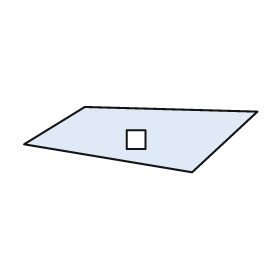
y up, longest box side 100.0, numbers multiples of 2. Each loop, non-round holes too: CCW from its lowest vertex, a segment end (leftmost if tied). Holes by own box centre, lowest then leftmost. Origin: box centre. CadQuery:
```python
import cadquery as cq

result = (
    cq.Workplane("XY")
    .moveTo(22.0, -14.0)
    .lineTo(50.0, 12.0)
    .lineTo(-24.0, 14.0)
    .lineTo(-50.0, -2.0)
    .close()
    .moveTo(-6.0, -4.0)
    .lineTo(2.0, -4.0)
    .lineTo(2.0, 4.0)
    .lineTo(-6.0, 4.0)
    .close()
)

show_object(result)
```